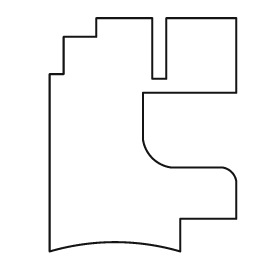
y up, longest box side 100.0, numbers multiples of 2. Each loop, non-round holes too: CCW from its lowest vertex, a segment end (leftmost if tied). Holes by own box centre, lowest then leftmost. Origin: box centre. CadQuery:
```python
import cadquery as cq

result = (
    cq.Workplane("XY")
    .moveTo(-40.0, -50.0)
    .threePointArc((-12.0, -46.0), (16.0, -50.0))
    .lineTo(16.0, -36.0)
    .lineTo(40.0, -36.0)
    .lineTo(40.0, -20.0)
    .threePointArc((38.0, -16.0), (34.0, -14.0))
    .lineTo(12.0, -14.0)
    .threePointArc((4.0, -10.0), (0.0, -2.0))
    .lineTo(0.0, 18.0)
    .lineTo(40.0, 18.0)
    .lineTo(40.0, 50.0)
    .lineTo(10.0, 50.0)
    .lineTo(10.0, 24.0)
    .lineTo(4.0, 24.0)
    .lineTo(4.0, 50.0)
    .lineTo(-20.0, 50.0)
    .lineTo(-20.0, 42.0)
    .lineTo(-34.0, 42.0)
    .lineTo(-34.0, 26.0)
    .lineTo(-40.0, 26.0)
    .close()
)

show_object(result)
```